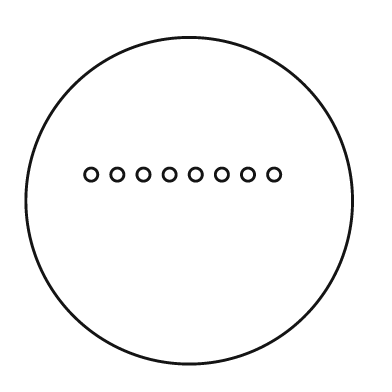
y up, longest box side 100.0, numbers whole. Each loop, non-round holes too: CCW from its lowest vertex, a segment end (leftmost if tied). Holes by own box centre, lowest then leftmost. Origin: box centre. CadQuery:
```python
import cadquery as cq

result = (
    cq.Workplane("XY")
    .moveTo(0.0, 0.0)
    .circle(50.0)
    .moveTo(-30.0, 8.0)
    .circle(2.0)
    .moveTo(-22.0, 8.0)
    .circle(2.0)
    .moveTo(-14.0, 8.0)
    .circle(2.0)
    .moveTo(-6.0, 8.0)
    .circle(2.0)
    .moveTo(2.0, 8.0)
    .circle(2.0)
    .moveTo(10.0, 8.0)
    .circle(2.0)
    .moveTo(18.0, 8.0)
    .circle(2.0)
    .moveTo(26.0, 8.0)
    .circle(2.0)
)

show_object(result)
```